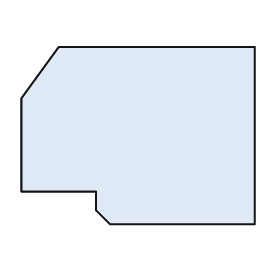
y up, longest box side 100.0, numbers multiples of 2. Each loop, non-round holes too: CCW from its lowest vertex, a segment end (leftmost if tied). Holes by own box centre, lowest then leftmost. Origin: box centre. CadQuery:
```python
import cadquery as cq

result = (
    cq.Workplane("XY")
    .moveTo(-12.0, -38.0)
    .lineTo(50.0, -38.0)
    .lineTo(50.0, 38.0)
    .lineTo(-34.0, 38.0)
    .lineTo(-50.0, 16.0)
    .lineTo(-50.0, -24.0)
    .lineTo(-18.0, -24.0)
    .lineTo(-18.0, -32.0)
    .close()
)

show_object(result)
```